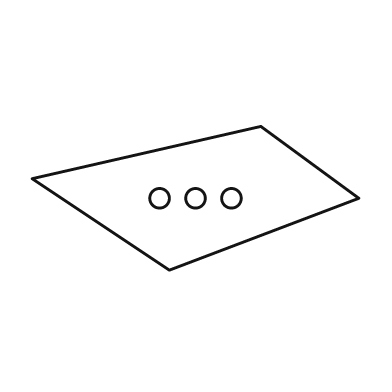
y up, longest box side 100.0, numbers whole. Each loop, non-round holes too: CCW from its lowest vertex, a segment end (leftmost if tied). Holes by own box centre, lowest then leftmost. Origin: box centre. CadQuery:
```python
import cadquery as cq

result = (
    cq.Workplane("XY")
    .moveTo(-8.0, -22.0)
    .lineTo(50.0, 0.0)
    .lineTo(20.0, 22.0)
    .lineTo(-50.0, 6.0)
    .close()
    .moveTo(-11.0, 0.0)
    .circle(3.0)
    .moveTo(0.0, 0.0)
    .circle(3.0)
    .moveTo(11.0, 0.0)
    .circle(3.0)
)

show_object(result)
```